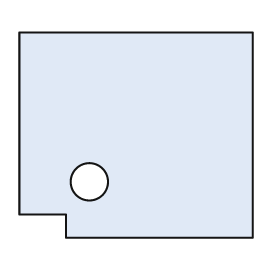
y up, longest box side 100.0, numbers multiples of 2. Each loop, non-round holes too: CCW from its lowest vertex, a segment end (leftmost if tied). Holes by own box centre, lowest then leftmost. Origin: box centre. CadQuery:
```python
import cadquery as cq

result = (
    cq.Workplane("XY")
    .moveTo(-30.0, -44.0)
    .lineTo(50.0, -44.0)
    .lineTo(50.0, 44.0)
    .lineTo(-50.0, 44.0)
    .lineTo(-50.0, -34.0)
    .lineTo(-30.0, -34.0)
    .close()
    .moveTo(-20.0, -20.0)
    .circle(8.0)
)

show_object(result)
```